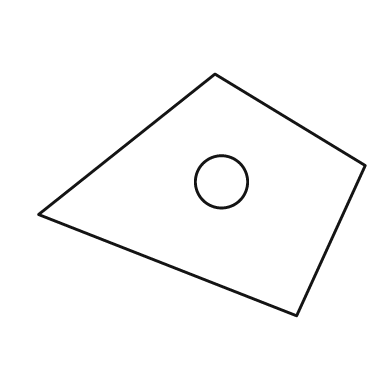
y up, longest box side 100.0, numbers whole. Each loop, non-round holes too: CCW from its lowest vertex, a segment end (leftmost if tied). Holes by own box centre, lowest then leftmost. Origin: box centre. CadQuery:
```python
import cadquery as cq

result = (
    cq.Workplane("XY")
    .moveTo(29.0, -37.0)
    .lineTo(50.0, 9.0)
    .lineTo(4.0, 37.0)
    .lineTo(-50.0, -6.0)
    .close()
    .moveTo(6.0, 4.0)
    .circle(8.0)
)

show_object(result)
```